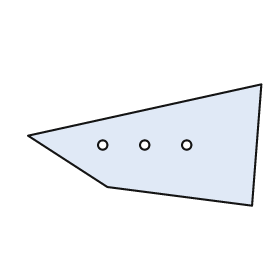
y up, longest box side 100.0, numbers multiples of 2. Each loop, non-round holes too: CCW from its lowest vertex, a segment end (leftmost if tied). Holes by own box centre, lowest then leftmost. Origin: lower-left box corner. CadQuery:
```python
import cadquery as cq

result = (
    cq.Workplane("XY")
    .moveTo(96.0, 0.0)
    .lineTo(100.0, 52.0)
    .lineTo(0.0, 30.0)
    .lineTo(34.0, 8.0)
    .close()
    .moveTo(32.0, 26.0)
    .circle(2.0)
    .moveTo(50.0, 26.0)
    .circle(2.0)
    .moveTo(68.0, 26.0)
    .circle(2.0)
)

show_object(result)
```